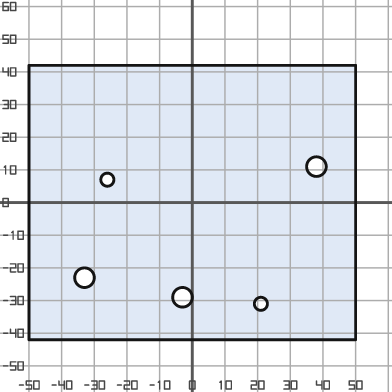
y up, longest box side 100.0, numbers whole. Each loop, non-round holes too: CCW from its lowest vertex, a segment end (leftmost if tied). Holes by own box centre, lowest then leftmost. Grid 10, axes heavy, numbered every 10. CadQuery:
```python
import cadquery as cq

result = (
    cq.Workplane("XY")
    .moveTo(-50.0, -42.0)
    .lineTo(50.0, -42.0)
    .lineTo(50.0, 42.0)
    .lineTo(-50.0, 42.0)
    .close()
    .moveTo(21.0, -31.0)
    .circle(2.0)
    .moveTo(-3.0, -29.0)
    .circle(3.0)
    .moveTo(-33.0, -23.0)
    .circle(3.0)
    .moveTo(-26.0, 7.0)
    .circle(2.0)
    .moveTo(38.0, 11.0)
    .circle(3.0)
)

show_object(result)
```